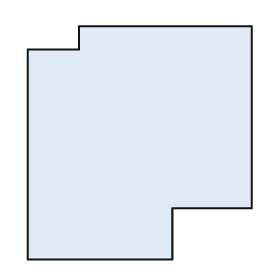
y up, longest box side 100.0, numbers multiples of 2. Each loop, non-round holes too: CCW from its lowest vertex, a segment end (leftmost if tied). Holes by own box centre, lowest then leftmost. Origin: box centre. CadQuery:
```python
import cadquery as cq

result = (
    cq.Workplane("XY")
    .moveTo(-48.0, -50.0)
    .lineTo(14.0, -50.0)
    .lineTo(14.0, -28.0)
    .lineTo(48.0, -28.0)
    .lineTo(48.0, 50.0)
    .lineTo(-26.0, 50.0)
    .lineTo(-26.0, 40.0)
    .lineTo(-48.0, 40.0)
    .close()
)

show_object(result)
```